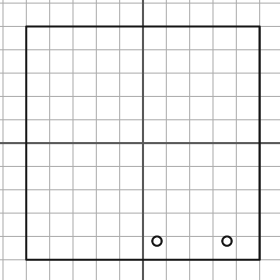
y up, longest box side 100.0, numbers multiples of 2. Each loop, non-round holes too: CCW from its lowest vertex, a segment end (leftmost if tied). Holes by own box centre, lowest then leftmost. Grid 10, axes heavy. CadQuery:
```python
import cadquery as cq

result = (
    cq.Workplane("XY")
    .moveTo(-50.0, -50.0)
    .lineTo(50.0, -50.0)
    .lineTo(50.0, 50.0)
    .lineTo(-50.0, 50.0)
    .close()
    .moveTo(6.0, -42.0)
    .circle(2.0)
    .moveTo(36.0, -42.0)
    .circle(2.0)
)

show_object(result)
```